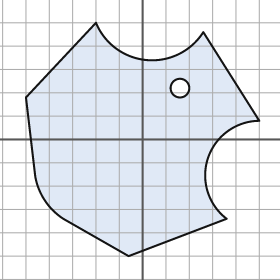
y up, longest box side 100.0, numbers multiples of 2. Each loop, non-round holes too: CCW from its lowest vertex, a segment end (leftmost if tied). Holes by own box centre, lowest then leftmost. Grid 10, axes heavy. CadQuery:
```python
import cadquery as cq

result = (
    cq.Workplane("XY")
    .moveTo(-6.0, -50.0)
    .lineTo(36.0, -34.0)
    .threePointArc((28.0, -8.0), (50.0, 8.0))
    .lineTo(26.0, 46.0)
    .threePointArc((2.0, 34.0), (-20.0, 50.0))
    .lineTo(-50.0, 18.0)
    .lineTo(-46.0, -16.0)
    .threePointArc((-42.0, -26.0), (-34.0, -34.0))
    .close()
    .moveTo(16.0, 22.0)
    .circle(4.0)
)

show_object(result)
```